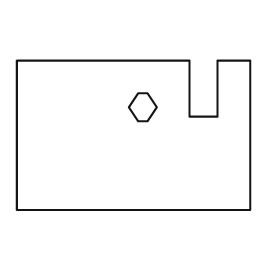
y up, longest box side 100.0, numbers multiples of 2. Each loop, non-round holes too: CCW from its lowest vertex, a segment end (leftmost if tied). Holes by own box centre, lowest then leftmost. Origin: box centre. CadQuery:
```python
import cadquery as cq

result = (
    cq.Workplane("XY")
    .moveTo(-50.0, -32.0)
    .lineTo(50.0, -32.0)
    .lineTo(50.0, 32.0)
    .lineTo(36.0, 32.0)
    .lineTo(36.0, 8.0)
    .lineTo(24.0, 8.0)
    .lineTo(24.0, 32.0)
    .lineTo(-50.0, 32.0)
    .close()
    .moveTo(2.0, 6.0)
    .lineTo(6.0, 6.0)
    .lineTo(10.0, 12.0)
    .lineTo(6.0, 18.0)
    .lineTo(2.0, 18.0)
    .lineTo(-2.0, 12.0)
    .close()
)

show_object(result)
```